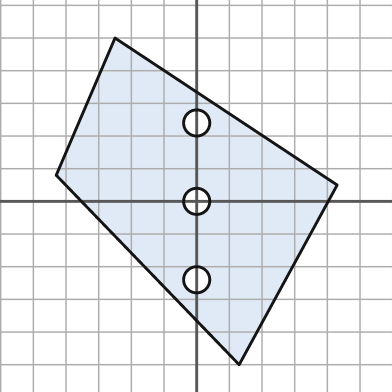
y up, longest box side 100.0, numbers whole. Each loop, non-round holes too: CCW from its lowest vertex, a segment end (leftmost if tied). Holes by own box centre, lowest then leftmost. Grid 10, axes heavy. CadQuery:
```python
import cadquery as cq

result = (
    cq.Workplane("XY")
    .moveTo(13.0, -50.0)
    .lineTo(43.0, 5.0)
    .lineTo(-25.0, 50.0)
    .lineTo(-43.0, 8.0)
    .close()
    .moveTo(0.0, -24.0)
    .circle(4.0)
    .moveTo(0.0, 0.0)
    .circle(4.0)
    .moveTo(0.0, 24.0)
    .circle(4.0)
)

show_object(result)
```